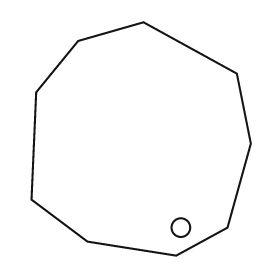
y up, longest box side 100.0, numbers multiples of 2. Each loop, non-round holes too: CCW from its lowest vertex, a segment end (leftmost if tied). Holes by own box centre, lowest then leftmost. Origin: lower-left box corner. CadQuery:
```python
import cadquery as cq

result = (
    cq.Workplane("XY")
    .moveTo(62.0, 0.0)
    .lineTo(84.0, 12.0)
    .lineTo(94.0, 48.0)
    .lineTo(88.0, 78.0)
    .lineTo(48.0, 100.0)
    .lineTo(20.0, 92.0)
    .lineTo(2.0, 70.0)
    .lineTo(0.0, 24.0)
    .lineTo(24.0, 6.0)
    .close()
    .moveTo(64.0, 12.0)
    .circle(4.0)
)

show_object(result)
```